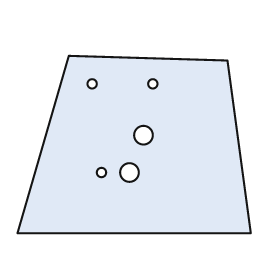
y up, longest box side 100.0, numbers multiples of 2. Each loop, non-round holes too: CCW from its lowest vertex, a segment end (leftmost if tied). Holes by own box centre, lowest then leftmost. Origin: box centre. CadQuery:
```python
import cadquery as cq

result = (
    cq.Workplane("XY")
    .moveTo(-50.0, -38.0)
    .lineTo(50.0, -38.0)
    .lineTo(40.0, 36.0)
    .lineTo(-28.0, 38.0)
    .close()
    .moveTo(-14.0, -12.0)
    .circle(2.0)
    .moveTo(-2.0, -12.0)
    .circle(4.0)
    .moveTo(4.0, 4.0)
    .circle(4.0)
    .moveTo(-18.0, 26.0)
    .circle(2.0)
    .moveTo(8.0, 26.0)
    .circle(2.0)
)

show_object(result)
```